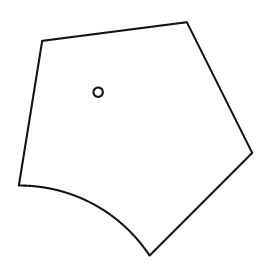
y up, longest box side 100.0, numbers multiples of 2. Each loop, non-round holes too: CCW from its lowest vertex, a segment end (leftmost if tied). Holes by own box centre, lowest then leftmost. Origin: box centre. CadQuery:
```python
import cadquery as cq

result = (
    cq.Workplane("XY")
    .moveTo(6.0, -50.0)
    .lineTo(50.0, -6.0)
    .lineTo(22.0, 50.0)
    .lineTo(-40.0, 42.0)
    .lineTo(-50.0, -20.0)
    .threePointArc((-18.0, -28.0), (6.0, -50.0))
    .close()
    .moveTo(-16.0, 20.0)
    .circle(2.0)
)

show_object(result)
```